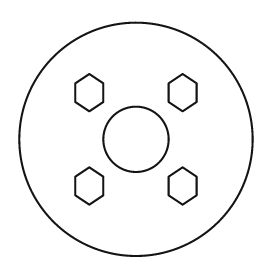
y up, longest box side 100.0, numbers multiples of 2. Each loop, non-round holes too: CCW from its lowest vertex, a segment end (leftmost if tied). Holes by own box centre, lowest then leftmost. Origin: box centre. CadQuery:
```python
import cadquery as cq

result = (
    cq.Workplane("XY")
    .moveTo(0.0, 0.0)
    .circle(50.0)
    .moveTo(-20.0, -28.0)
    .lineTo(-14.0, -24.0)
    .lineTo(-14.0, -16.0)
    .lineTo(-20.0, -12.0)
    .lineTo(-26.0, -16.0)
    .lineTo(-26.0, -24.0)
    .close()
    .moveTo(20.0, -28.0)
    .lineTo(26.0, -24.0)
    .lineTo(26.0, -16.0)
    .lineTo(20.0, -12.0)
    .lineTo(14.0, -16.0)
    .lineTo(14.0, -24.0)
    .close()
    .moveTo(0.0, 0.0)
    .circle(14.0)
    .moveTo(-20.0, 12.0)
    .lineTo(-14.0, 16.0)
    .lineTo(-14.0, 24.0)
    .lineTo(-20.0, 28.0)
    .lineTo(-26.0, 24.0)
    .lineTo(-26.0, 16.0)
    .close()
    .moveTo(20.0, 12.0)
    .lineTo(26.0, 16.0)
    .lineTo(26.0, 24.0)
    .lineTo(20.0, 28.0)
    .lineTo(14.0, 24.0)
    .lineTo(14.0, 16.0)
    .close()
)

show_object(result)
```